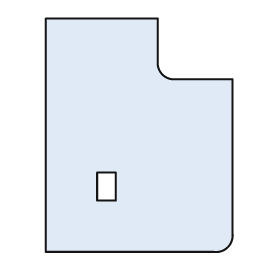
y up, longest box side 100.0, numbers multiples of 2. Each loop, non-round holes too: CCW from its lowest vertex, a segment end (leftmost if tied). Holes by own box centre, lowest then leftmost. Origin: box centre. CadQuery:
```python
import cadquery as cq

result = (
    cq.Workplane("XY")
    .moveTo(-40.0, -50.0)
    .lineTo(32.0, -50.0)
    .threePointArc((38.0, -48.0), (40.0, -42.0))
    .lineTo(40.0, 24.0)
    .lineTo(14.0, 24.0)
    .threePointArc((10.0, 26.0), (8.0, 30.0))
    .lineTo(8.0, 50.0)
    .lineTo(-40.0, 50.0)
    .close()
    .moveTo(-18.0, -28.0)
    .lineTo(-10.0, -28.0)
    .lineTo(-10.0, -16.0)
    .lineTo(-18.0, -16.0)
    .close()
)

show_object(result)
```